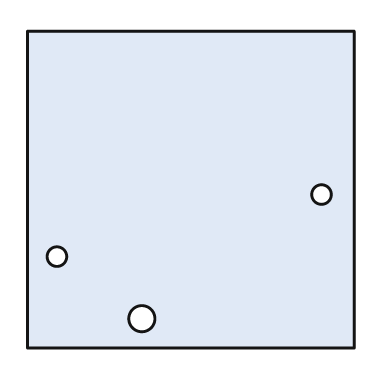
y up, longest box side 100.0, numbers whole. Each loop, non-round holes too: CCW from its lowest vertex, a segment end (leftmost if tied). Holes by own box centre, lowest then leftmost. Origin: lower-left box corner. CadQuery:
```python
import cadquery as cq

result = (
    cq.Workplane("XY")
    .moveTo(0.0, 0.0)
    .lineTo(100.0, 0.0)
    .lineTo(100.0, 97.0)
    .lineTo(0.0, 97.0)
    .close()
    .moveTo(35.0, 9.0)
    .circle(4.0)
    .moveTo(9.0, 28.0)
    .circle(3.0)
    .moveTo(90.0, 47.0)
    .circle(3.0)
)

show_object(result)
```